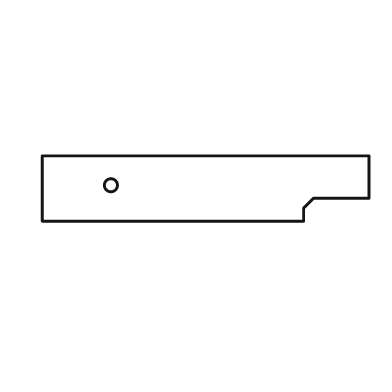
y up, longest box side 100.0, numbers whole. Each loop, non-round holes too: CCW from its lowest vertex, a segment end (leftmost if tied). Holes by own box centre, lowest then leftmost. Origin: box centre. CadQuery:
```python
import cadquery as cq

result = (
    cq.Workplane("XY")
    .moveTo(-50.0, -10.0)
    .lineTo(30.0, -10.0)
    .lineTo(30.0, -6.0)
    .lineTo(33.0, -3.0)
    .lineTo(50.0, -3.0)
    .lineTo(50.0, 10.0)
    .lineTo(-50.0, 10.0)
    .close()
    .moveTo(-29.0, 1.0)
    .circle(2.0)
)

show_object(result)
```